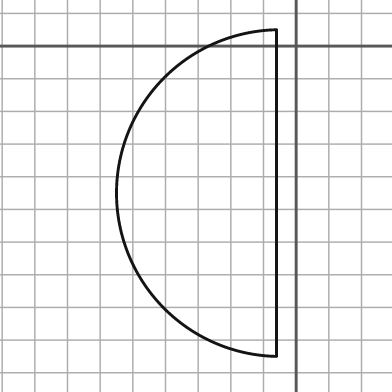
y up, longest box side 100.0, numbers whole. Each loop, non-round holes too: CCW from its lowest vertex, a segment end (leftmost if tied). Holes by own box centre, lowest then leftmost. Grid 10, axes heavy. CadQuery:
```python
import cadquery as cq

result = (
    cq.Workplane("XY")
    .moveTo(-6.0, -95.0)
    .lineTo(-6.0, 5.0)
    .threePointArc((-55.0, -45.0), (-6.0, -95.0))
    .close()
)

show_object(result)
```